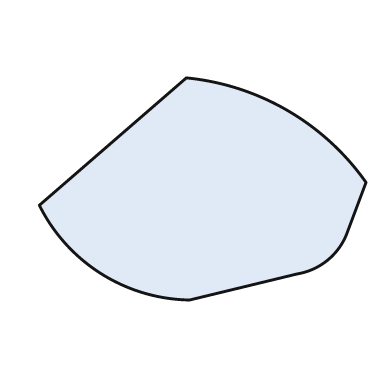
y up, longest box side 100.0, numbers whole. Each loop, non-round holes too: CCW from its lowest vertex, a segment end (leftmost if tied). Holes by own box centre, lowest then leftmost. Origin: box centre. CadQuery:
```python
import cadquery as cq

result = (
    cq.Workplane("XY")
    .moveTo(-4.0, -34.0)
    .lineTo(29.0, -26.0)
    .threePointArc((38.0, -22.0), (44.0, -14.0))
    .lineTo(50.0, 2.0)
    .threePointArc((26.0, 24.0), (-5.0, 34.0))
    .lineTo(-50.0, -5.0)
    .threePointArc((-31.0, -26.0), (-4.0, -34.0))
    .close()
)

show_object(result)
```